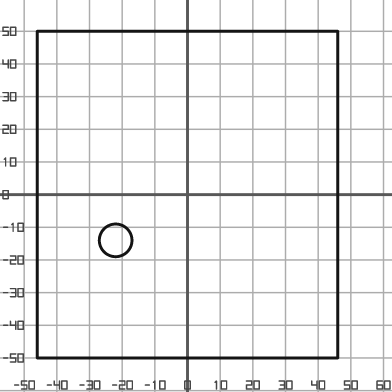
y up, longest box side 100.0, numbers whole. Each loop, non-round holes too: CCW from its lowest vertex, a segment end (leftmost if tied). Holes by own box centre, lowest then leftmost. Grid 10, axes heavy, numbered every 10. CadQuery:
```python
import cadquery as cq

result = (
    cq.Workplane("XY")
    .moveTo(-46.0, -50.0)
    .lineTo(46.0, -50.0)
    .lineTo(46.0, 50.0)
    .lineTo(-46.0, 50.0)
    .close()
    .moveTo(-22.0, -14.0)
    .circle(5.0)
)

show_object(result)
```